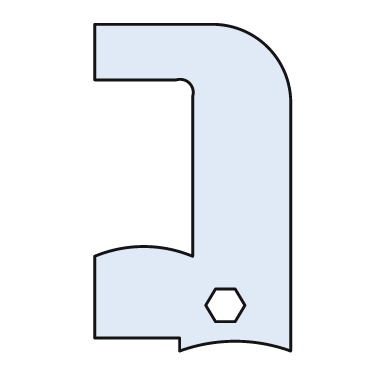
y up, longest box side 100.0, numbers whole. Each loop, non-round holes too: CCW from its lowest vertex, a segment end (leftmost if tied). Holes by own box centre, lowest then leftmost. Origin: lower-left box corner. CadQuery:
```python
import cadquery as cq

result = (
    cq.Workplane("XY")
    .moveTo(26.0, 0.0)
    .threePointArc((43.0, 3.0), (60.0, 0.0))
    .lineTo(60.0, 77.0)
    .threePointArc((53.0, 93.0), (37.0, 100.0))
    .lineTo(0.0, 100.0)
    .lineTo(0.0, 83.0)
    .lineTo(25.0, 83.0)
    .threePointArc((29.0, 82.0), (30.0, 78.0))
    .lineTo(30.0, 29.0)
    .threePointArc((15.0, 32.0), (0.0, 29.0))
    .lineTo(0.0, 4.0)
    .lineTo(26.0, 4.0)
    .close()
    .moveTo(37.0, 9.0)
    .lineTo(43.0, 9.0)
    .lineTo(46.0, 14.0)
    .lineTo(43.0, 19.0)
    .lineTo(37.0, 19.0)
    .lineTo(34.0, 14.0)
    .close()
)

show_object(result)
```